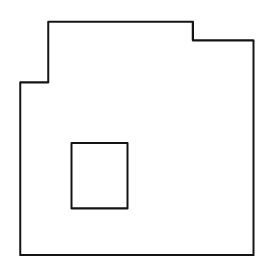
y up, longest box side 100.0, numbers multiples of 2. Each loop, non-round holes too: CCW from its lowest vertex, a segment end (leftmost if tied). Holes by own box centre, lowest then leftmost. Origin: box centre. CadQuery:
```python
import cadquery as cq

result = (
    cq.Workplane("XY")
    .moveTo(-50.0, -50.0)
    .lineTo(50.0, -50.0)
    .lineTo(50.0, 42.0)
    .lineTo(24.0, 42.0)
    .lineTo(24.0, 50.0)
    .lineTo(-38.0, 50.0)
    .lineTo(-38.0, 24.0)
    .lineTo(-50.0, 24.0)
    .close()
    .moveTo(-28.0, -30.0)
    .lineTo(-4.0, -30.0)
    .lineTo(-4.0, -2.0)
    .lineTo(-28.0, -2.0)
    .close()
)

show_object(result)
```